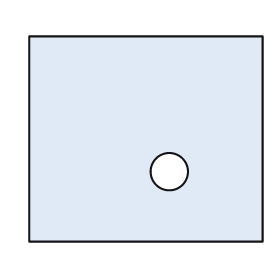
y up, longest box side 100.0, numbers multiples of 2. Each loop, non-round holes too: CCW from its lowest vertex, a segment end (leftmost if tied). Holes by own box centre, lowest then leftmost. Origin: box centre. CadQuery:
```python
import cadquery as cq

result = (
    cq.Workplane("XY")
    .moveTo(-50.0, -44.0)
    .lineTo(50.0, -44.0)
    .lineTo(50.0, 44.0)
    .lineTo(-50.0, 44.0)
    .close()
    .moveTo(10.0, -14.0)
    .circle(8.0)
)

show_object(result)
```